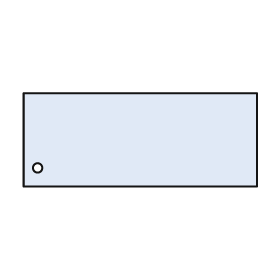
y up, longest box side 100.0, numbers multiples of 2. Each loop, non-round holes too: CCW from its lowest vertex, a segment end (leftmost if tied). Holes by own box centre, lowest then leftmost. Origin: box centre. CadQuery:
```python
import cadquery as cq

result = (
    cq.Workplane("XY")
    .moveTo(-50.0, -20.0)
    .lineTo(50.0, -20.0)
    .lineTo(50.0, 20.0)
    .lineTo(-50.0, 20.0)
    .close()
    .moveTo(-44.0, -12.0)
    .circle(2.0)
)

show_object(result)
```